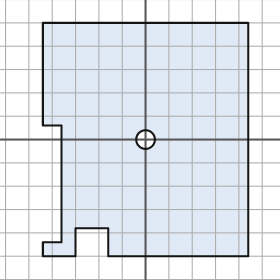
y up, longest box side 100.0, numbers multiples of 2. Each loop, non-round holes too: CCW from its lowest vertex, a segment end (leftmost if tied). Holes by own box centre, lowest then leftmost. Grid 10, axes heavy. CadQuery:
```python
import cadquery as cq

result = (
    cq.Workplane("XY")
    .moveTo(-44.0, -50.0)
    .lineTo(-30.0, -50.0)
    .lineTo(-30.0, -38.0)
    .lineTo(-16.0, -38.0)
    .lineTo(-16.0, -50.0)
    .lineTo(44.0, -50.0)
    .lineTo(44.0, 50.0)
    .lineTo(-44.0, 50.0)
    .lineTo(-44.0, 6.0)
    .lineTo(-36.0, 6.0)
    .lineTo(-36.0, -44.0)
    .lineTo(-44.0, -44.0)
    .close()
    .moveTo(0.0, 0.0)
    .circle(4.0)
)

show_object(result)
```